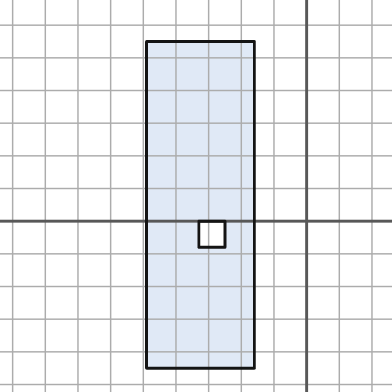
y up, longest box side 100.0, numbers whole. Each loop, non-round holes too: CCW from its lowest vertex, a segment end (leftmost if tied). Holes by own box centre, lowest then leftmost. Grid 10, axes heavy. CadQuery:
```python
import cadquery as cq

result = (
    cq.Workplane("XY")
    .moveTo(-49.0, -45.0)
    .lineTo(-16.0, -45.0)
    .lineTo(-16.0, 55.0)
    .lineTo(-49.0, 55.0)
    .close()
    .moveTo(-33.0, -8.0)
    .lineTo(-25.0, -8.0)
    .lineTo(-25.0, 0.0)
    .lineTo(-33.0, 0.0)
    .close()
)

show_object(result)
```